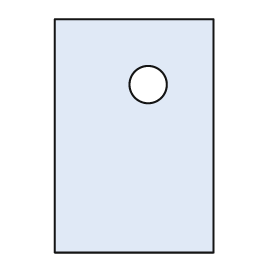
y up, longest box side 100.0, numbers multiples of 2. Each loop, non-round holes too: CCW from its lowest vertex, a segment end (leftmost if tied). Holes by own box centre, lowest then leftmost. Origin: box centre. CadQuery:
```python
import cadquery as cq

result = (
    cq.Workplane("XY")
    .moveTo(-34.0, -50.0)
    .lineTo(34.0, -50.0)
    .lineTo(34.0, 50.0)
    .lineTo(-34.0, 50.0)
    .close()
    .moveTo(6.0, 22.0)
    .circle(8.0)
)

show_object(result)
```